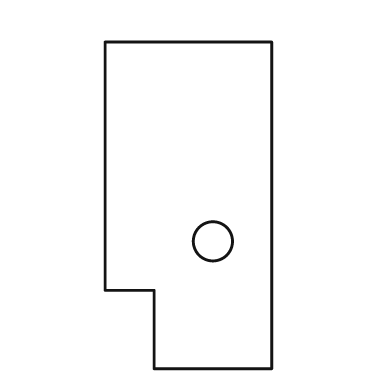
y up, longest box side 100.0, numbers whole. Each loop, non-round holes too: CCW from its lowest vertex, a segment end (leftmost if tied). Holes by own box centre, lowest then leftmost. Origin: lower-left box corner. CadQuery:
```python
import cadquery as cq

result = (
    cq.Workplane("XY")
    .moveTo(15.0, 0.0)
    .lineTo(51.0, 0.0)
    .lineTo(51.0, 100.0)
    .lineTo(0.0, 100.0)
    .lineTo(0.0, 24.0)
    .lineTo(15.0, 24.0)
    .close()
    .moveTo(33.0, 39.0)
    .circle(6.0)
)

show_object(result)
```